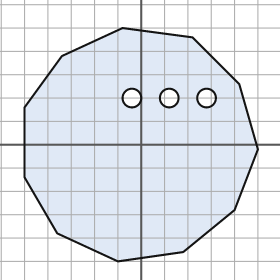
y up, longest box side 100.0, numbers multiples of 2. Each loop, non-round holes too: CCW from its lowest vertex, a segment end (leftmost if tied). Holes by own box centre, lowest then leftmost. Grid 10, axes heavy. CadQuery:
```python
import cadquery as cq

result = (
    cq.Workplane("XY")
    .moveTo(-10.0, -50.0)
    .lineTo(18.0, -46.0)
    .lineTo(40.0, -28.0)
    .lineTo(50.0, -2.0)
    .lineTo(42.0, 26.0)
    .lineTo(22.0, 46.0)
    .lineTo(-8.0, 50.0)
    .lineTo(-34.0, 38.0)
    .lineTo(-50.0, 16.0)
    .lineTo(-50.0, -14.0)
    .lineTo(-36.0, -38.0)
    .close()
    .moveTo(-4.0, 20.0)
    .circle(4.0)
    .moveTo(12.0, 20.0)
    .circle(4.0)
    .moveTo(28.0, 20.0)
    .circle(4.0)
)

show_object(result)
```